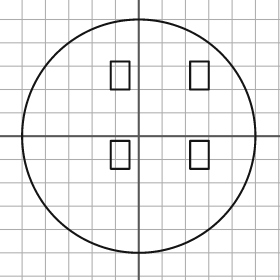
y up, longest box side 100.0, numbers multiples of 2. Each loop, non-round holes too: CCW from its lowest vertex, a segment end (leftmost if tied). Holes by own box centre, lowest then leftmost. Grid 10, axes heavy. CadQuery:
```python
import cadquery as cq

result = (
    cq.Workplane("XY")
    .moveTo(0.0, 0.0)
    .circle(50.0)
    .moveTo(-12.0, -14.0)
    .lineTo(-4.0, -14.0)
    .lineTo(-4.0, -2.0)
    .lineTo(-12.0, -2.0)
    .close()
    .moveTo(22.0, -14.0)
    .lineTo(30.0, -14.0)
    .lineTo(30.0, -2.0)
    .lineTo(22.0, -2.0)
    .close()
    .moveTo(-12.0, 20.0)
    .lineTo(-4.0, 20.0)
    .lineTo(-4.0, 32.0)
    .lineTo(-12.0, 32.0)
    .close()
    .moveTo(22.0, 20.0)
    .lineTo(30.0, 20.0)
    .lineTo(30.0, 32.0)
    .lineTo(22.0, 32.0)
    .close()
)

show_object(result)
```